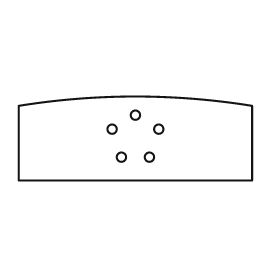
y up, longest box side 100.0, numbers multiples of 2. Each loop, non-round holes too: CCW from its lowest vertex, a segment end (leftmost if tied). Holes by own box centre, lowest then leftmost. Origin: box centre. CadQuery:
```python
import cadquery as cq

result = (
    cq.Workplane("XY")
    .moveTo(-50.0, -18.0)
    .lineTo(50.0, -18.0)
    .lineTo(50.0, 14.0)
    .threePointArc((0.0, 18.0), (-50.0, 14.0))
    .close()
    .moveTo(-6.0, -8.0)
    .circle(2.0)
    .moveTo(6.0, -8.0)
    .circle(2.0)
    .moveTo(-10.0, 4.0)
    .circle(2.0)
    .moveTo(10.0, 4.0)
    .circle(2.0)
    .moveTo(0.0, 10.0)
    .circle(2.0)
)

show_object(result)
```